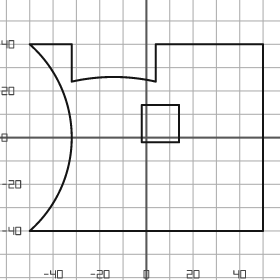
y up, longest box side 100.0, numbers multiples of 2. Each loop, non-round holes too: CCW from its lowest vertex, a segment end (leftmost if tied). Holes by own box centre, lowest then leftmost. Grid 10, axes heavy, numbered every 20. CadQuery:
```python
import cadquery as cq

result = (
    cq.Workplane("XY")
    .moveTo(-50.0, -40.0)
    .lineTo(50.0, -40.0)
    .lineTo(50.0, 40.0)
    .lineTo(4.0, 40.0)
    .lineTo(4.0, 24.0)
    .threePointArc((-14.0, 26.0), (-32.0, 24.0))
    .lineTo(-32.0, 40.0)
    .lineTo(-50.0, 40.0)
    .threePointArc((-32.0, 0.0), (-50.0, -40.0))
    .close()
    .moveTo(-2.0, -2.0)
    .lineTo(14.0, -2.0)
    .lineTo(14.0, 14.0)
    .lineTo(-2.0, 14.0)
    .close()
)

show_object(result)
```